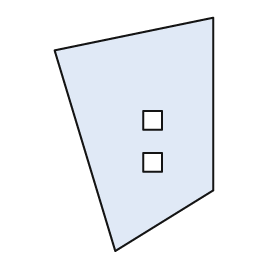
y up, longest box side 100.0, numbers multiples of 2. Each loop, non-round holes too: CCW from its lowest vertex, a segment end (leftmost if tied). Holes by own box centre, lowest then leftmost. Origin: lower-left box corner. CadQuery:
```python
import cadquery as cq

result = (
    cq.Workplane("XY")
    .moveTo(26.0, 0.0)
    .lineTo(68.0, 26.0)
    .lineTo(68.0, 100.0)
    .lineTo(0.0, 86.0)
    .close()
    .moveTo(38.0, 34.0)
    .lineTo(46.0, 34.0)
    .lineTo(46.0, 42.0)
    .lineTo(38.0, 42.0)
    .close()
    .moveTo(38.0, 52.0)
    .lineTo(46.0, 52.0)
    .lineTo(46.0, 60.0)
    .lineTo(38.0, 60.0)
    .close()
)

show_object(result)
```